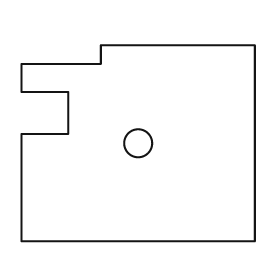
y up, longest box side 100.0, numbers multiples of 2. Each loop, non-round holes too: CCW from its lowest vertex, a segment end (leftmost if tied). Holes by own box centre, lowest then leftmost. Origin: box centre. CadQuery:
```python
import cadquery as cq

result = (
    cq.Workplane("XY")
    .moveTo(-50.0, -42.0)
    .lineTo(50.0, -42.0)
    .lineTo(50.0, 42.0)
    .lineTo(-16.0, 42.0)
    .lineTo(-16.0, 34.0)
    .lineTo(-50.0, 34.0)
    .lineTo(-50.0, 22.0)
    .lineTo(-30.0, 22.0)
    .lineTo(-30.0, 4.0)
    .lineTo(-50.0, 4.0)
    .close()
    .moveTo(0.0, 0.0)
    .circle(6.0)
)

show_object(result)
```